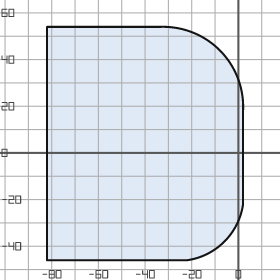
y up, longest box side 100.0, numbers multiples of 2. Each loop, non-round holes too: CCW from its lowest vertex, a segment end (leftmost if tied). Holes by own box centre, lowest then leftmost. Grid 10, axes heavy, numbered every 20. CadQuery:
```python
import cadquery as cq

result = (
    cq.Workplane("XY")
    .moveTo(-82.0, -46.0)
    .lineTo(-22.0, -46.0)
    .threePointArc((-6.0, -38.0), (2.0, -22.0))
    .lineTo(2.0, 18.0)
    .threePointArc((-8.0, 44.0), (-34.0, 54.0))
    .lineTo(-82.0, 54.0)
    .close()
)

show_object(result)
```